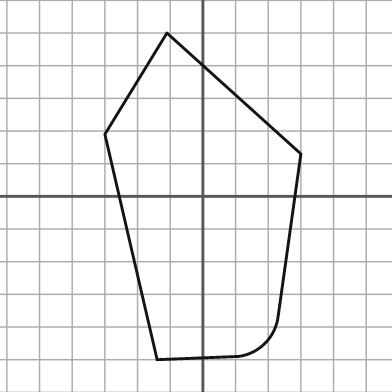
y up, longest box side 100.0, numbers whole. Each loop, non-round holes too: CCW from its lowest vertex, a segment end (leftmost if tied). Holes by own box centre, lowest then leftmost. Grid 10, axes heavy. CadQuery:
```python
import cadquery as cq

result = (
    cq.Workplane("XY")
    .moveTo(-14.0, -50.0)
    .lineTo(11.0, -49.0)
    .threePointArc((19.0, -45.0), (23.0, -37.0))
    .lineTo(30.0, 13.0)
    .lineTo(-11.0, 50.0)
    .lineTo(-30.0, 19.0)
    .close()
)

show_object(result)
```